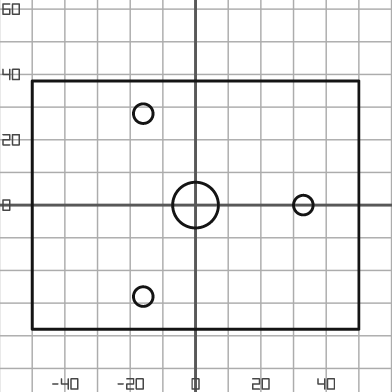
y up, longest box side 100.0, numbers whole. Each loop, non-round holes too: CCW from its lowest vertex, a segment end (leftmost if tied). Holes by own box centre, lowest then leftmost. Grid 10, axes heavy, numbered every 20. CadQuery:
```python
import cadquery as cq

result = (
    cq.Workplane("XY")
    .moveTo(-50.0, -38.0)
    .lineTo(50.0, -38.0)
    .lineTo(50.0, 38.0)
    .lineTo(-50.0, 38.0)
    .close()
    .moveTo(-16.0, -28.0)
    .circle(3.0)
    .moveTo(0.0, 0.0)
    .circle(7.0)
    .moveTo(33.0, 0.0)
    .circle(3.0)
    .moveTo(-16.0, 28.0)
    .circle(3.0)
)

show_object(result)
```